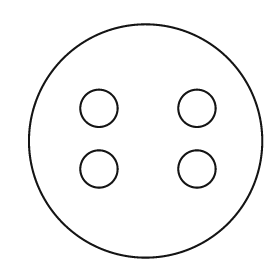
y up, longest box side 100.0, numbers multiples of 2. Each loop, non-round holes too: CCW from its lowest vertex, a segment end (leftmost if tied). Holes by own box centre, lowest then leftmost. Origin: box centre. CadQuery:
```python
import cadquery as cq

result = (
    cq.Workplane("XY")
    .moveTo(0.0, 0.0)
    .circle(50.0)
    .moveTo(-20.0, -12.0)
    .circle(8.0)
    .moveTo(22.0, -12.0)
    .circle(8.0)
    .moveTo(-20.0, 14.0)
    .circle(8.0)
    .moveTo(22.0, 14.0)
    .circle(8.0)
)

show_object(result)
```